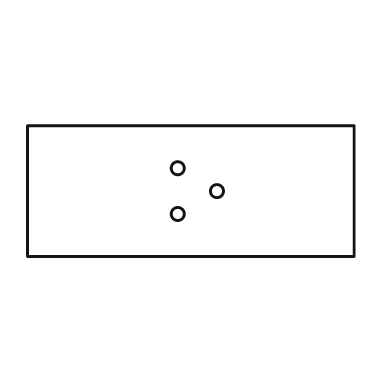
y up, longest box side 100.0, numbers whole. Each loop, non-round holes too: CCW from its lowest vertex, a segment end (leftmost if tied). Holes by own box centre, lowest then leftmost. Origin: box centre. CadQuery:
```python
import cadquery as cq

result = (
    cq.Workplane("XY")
    .moveTo(-50.0, -20.0)
    .lineTo(50.0, -20.0)
    .lineTo(50.0, 20.0)
    .lineTo(-50.0, 20.0)
    .close()
    .moveTo(-4.0, -7.0)
    .circle(2.0)
    .moveTo(8.0, 0.0)
    .circle(2.0)
    .moveTo(-4.0, 7.0)
    .circle(2.0)
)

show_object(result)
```